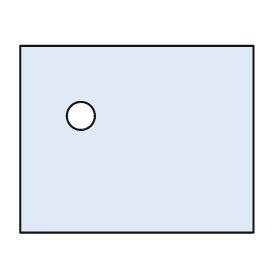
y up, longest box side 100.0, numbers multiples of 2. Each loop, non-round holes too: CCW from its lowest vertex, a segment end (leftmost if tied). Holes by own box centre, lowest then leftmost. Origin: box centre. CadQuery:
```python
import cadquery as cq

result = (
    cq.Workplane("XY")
    .moveTo(-50.0, -40.0)
    .lineTo(50.0, -40.0)
    .lineTo(50.0, 40.0)
    .lineTo(-50.0, 40.0)
    .close()
    .moveTo(-24.0, 10.0)
    .circle(6.0)
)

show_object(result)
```